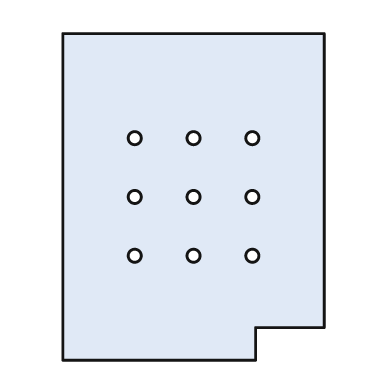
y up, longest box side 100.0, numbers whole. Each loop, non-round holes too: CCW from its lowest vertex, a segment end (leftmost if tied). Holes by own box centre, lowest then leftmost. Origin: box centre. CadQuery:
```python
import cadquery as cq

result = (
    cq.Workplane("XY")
    .moveTo(-40.0, -50.0)
    .lineTo(19.0, -50.0)
    .lineTo(19.0, -40.0)
    .lineTo(40.0, -40.0)
    .lineTo(40.0, 50.0)
    .lineTo(-40.0, 50.0)
    .close()
    .moveTo(-18.0, -18.0)
    .circle(2.0)
    .moveTo(0.0, -18.0)
    .circle(2.0)
    .moveTo(18.0, -18.0)
    .circle(2.0)
    .moveTo(-18.0, 0.0)
    .circle(2.0)
    .moveTo(0.0, 0.0)
    .circle(2.0)
    .moveTo(18.0, 0.0)
    .circle(2.0)
    .moveTo(-18.0, 18.0)
    .circle(2.0)
    .moveTo(0.0, 18.0)
    .circle(2.0)
    .moveTo(18.0, 18.0)
    .circle(2.0)
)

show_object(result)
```